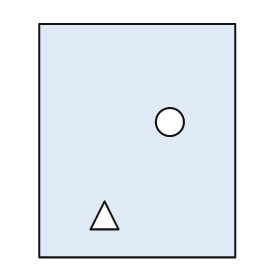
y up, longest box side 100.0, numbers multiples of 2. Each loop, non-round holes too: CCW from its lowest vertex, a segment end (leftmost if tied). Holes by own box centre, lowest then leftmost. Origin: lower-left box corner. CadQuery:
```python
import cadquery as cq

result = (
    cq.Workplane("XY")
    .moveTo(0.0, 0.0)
    .lineTo(84.0, 0.0)
    .lineTo(84.0, 100.0)
    .lineTo(0.0, 100.0)
    .close()
    .moveTo(22.0, 12.0)
    .lineTo(34.0, 12.0)
    .lineTo(28.0, 24.0)
    .close()
    .moveTo(56.0, 58.0)
    .circle(6.0)
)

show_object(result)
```